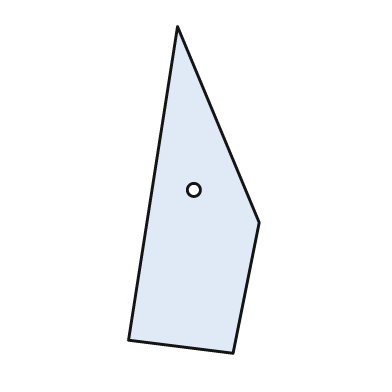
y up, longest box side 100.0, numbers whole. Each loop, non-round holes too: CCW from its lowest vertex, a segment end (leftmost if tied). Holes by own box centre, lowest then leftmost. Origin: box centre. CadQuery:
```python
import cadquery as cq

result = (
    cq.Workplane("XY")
    .moveTo(12.0, -50.0)
    .lineTo(20.0, -10.0)
    .lineTo(-5.0, 50.0)
    .lineTo(-20.0, -46.0)
    .close()
    .moveTo(0.0, 0.0)
    .circle(2.0)
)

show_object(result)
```